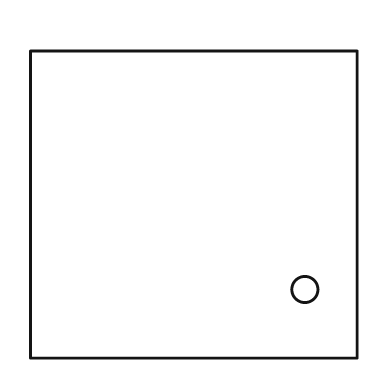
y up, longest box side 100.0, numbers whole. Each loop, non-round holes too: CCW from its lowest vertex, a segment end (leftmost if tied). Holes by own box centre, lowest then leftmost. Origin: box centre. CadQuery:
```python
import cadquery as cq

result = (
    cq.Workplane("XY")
    .moveTo(-50.0, -47.0)
    .lineTo(50.0, -47.0)
    .lineTo(50.0, 47.0)
    .lineTo(-50.0, 47.0)
    .close()
    .moveTo(34.0, -26.0)
    .circle(4.0)
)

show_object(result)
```